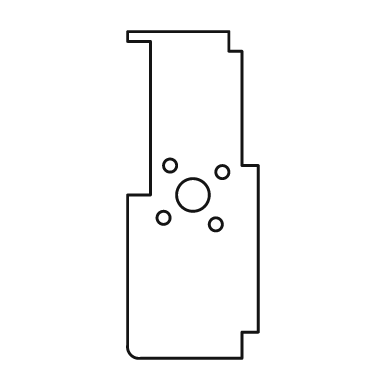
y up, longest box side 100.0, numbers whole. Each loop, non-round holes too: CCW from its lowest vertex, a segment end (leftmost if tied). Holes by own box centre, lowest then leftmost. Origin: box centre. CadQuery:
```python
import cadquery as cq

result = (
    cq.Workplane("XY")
    .moveTo(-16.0, -50.0)
    .lineTo(15.0, -50.0)
    .lineTo(15.0, -42.0)
    .lineTo(20.0, -42.0)
    .lineTo(20.0, 9.0)
    .lineTo(15.0, 9.0)
    .lineTo(15.0, 44.0)
    .lineTo(11.0, 44.0)
    .lineTo(11.0, 50.0)
    .lineTo(-20.0, 50.0)
    .lineTo(-20.0, 47.0)
    .lineTo(-13.0, 47.0)
    .lineTo(-13.0, 0.0)
    .lineTo(-20.0, 0.0)
    .lineTo(-20.0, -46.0)
    .threePointArc((-19.0, -49.0), (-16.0, -50.0))
    .close()
    .moveTo(7.0, -9.0)
    .circle(2.0)
    .moveTo(-9.0, -7.0)
    .circle(2.0)
    .moveTo(0.0, 0.0)
    .circle(5.0)
    .moveTo(9.0, 7.0)
    .circle(2.0)
    .moveTo(-7.0, 9.0)
    .circle(2.0)
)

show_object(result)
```